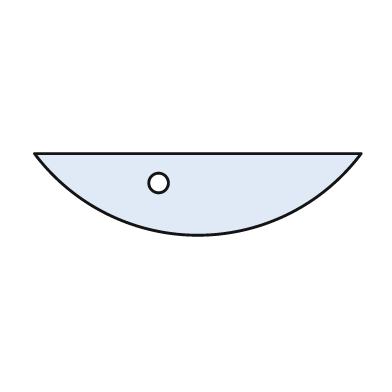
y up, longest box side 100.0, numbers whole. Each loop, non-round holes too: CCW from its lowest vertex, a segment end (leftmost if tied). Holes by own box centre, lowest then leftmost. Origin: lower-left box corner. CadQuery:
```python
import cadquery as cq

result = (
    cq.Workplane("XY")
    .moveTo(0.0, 25.0)
    .threePointArc((50.0, 0.0), (100.0, 25.0))
    .close()
    .moveTo(38.0, 16.0)
    .circle(3.0)
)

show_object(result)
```